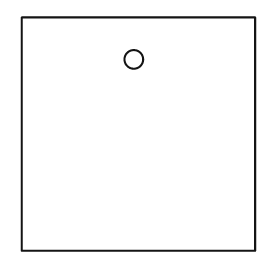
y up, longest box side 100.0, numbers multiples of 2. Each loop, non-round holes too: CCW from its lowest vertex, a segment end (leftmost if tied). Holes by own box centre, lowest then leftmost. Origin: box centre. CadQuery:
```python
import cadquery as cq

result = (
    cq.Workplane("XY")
    .moveTo(-50.0, -50.0)
    .lineTo(50.0, -50.0)
    .lineTo(50.0, 50.0)
    .lineTo(-50.0, 50.0)
    .close()
    .moveTo(-2.0, 32.0)
    .circle(4.0)
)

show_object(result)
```